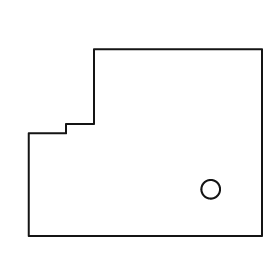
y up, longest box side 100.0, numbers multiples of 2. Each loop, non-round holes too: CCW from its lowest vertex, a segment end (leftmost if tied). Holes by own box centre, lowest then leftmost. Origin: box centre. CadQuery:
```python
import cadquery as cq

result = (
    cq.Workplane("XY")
    .moveTo(-50.0, -40.0)
    .lineTo(50.0, -40.0)
    .lineTo(50.0, 40.0)
    .lineTo(-22.0, 40.0)
    .lineTo(-22.0, 8.0)
    .lineTo(-34.0, 8.0)
    .lineTo(-34.0, 4.0)
    .lineTo(-50.0, 4.0)
    .close()
    .moveTo(28.0, -20.0)
    .circle(4.0)
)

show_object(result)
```